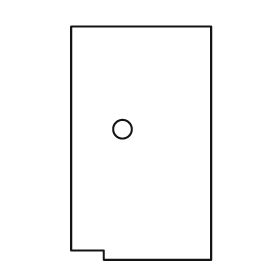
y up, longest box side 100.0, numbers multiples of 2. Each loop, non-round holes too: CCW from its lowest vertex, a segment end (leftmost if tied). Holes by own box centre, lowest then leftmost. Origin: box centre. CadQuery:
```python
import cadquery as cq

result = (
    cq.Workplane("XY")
    .moveTo(-16.0, -50.0)
    .lineTo(30.0, -50.0)
    .lineTo(30.0, 50.0)
    .lineTo(-30.0, 50.0)
    .lineTo(-30.0, -46.0)
    .lineTo(-16.0, -46.0)
    .close()
    .moveTo(-8.0, 6.0)
    .circle(4.0)
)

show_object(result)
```